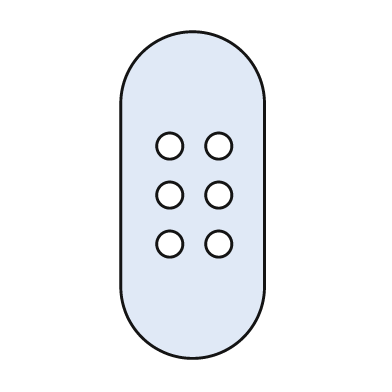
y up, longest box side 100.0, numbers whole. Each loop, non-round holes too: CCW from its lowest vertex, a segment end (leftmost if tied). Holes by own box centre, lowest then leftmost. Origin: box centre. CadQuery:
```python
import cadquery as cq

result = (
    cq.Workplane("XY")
    .moveTo(-22.0, -28.0)
    .threePointArc((0.0, -50.0), (22.0, -28.0))
    .lineTo(22.0, 28.0)
    .threePointArc((0.0, 50.0), (-22.0, 28.0))
    .close()
    .moveTo(-7.0, -15.0)
    .circle(4.0)
    .moveTo(8.0, -15.0)
    .circle(4.0)
    .moveTo(-7.0, 0.0)
    .circle(4.0)
    .moveTo(8.0, 0.0)
    .circle(4.0)
    .moveTo(-7.0, 15.0)
    .circle(4.0)
    .moveTo(8.0, 15.0)
    .circle(4.0)
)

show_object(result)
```